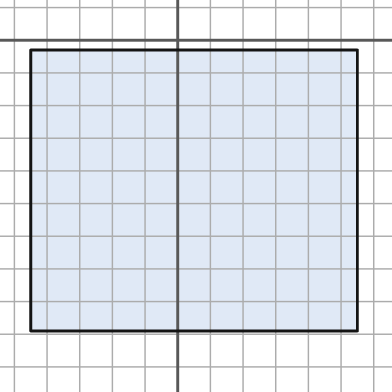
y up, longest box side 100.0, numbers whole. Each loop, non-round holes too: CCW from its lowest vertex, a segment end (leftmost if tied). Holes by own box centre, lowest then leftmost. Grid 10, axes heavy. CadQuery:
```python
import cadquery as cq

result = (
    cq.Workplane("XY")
    .moveTo(-45.0, -89.0)
    .lineTo(55.0, -89.0)
    .lineTo(55.0, -3.0)
    .lineTo(-45.0, -3.0)
    .close()
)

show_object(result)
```